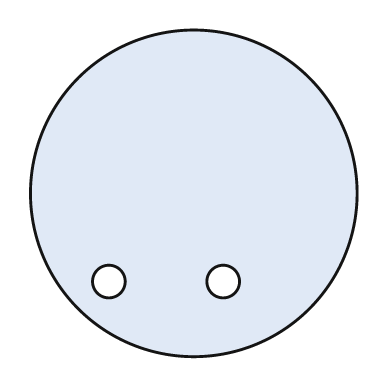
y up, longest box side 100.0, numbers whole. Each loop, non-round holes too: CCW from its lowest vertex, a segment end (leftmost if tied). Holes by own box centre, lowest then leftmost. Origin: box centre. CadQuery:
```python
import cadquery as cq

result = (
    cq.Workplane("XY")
    .moveTo(0.0, 0.0)
    .circle(50.0)
    .moveTo(-26.0, -27.0)
    .circle(5.0)
    .moveTo(9.0, -27.0)
    .circle(5.0)
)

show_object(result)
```